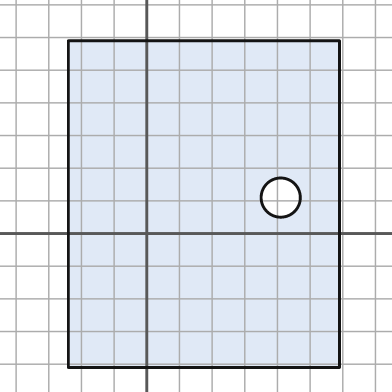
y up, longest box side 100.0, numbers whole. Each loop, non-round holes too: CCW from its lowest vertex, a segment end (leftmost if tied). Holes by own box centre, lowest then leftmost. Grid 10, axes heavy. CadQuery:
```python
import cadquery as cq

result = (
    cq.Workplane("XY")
    .moveTo(-24.0, -41.0)
    .lineTo(59.0, -41.0)
    .lineTo(59.0, 59.0)
    .lineTo(-24.0, 59.0)
    .close()
    .moveTo(41.0, 11.0)
    .circle(6.0)
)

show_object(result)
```